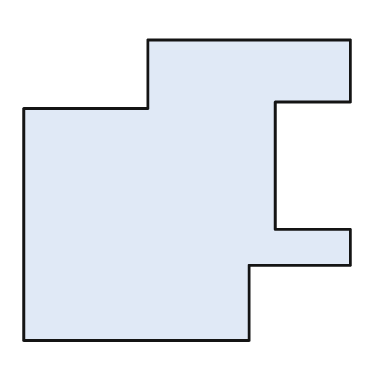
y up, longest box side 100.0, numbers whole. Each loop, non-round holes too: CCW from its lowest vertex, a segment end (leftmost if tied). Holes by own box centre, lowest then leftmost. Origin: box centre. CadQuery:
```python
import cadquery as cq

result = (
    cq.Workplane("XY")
    .moveTo(-50.0, -46.0)
    .lineTo(19.0, -46.0)
    .lineTo(19.0, -23.0)
    .lineTo(50.0, -23.0)
    .lineTo(50.0, -12.0)
    .lineTo(27.0, -12.0)
    .lineTo(27.0, 27.0)
    .lineTo(50.0, 27.0)
    .lineTo(50.0, 46.0)
    .lineTo(-12.0, 46.0)
    .lineTo(-12.0, 25.0)
    .lineTo(-50.0, 25.0)
    .close()
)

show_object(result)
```